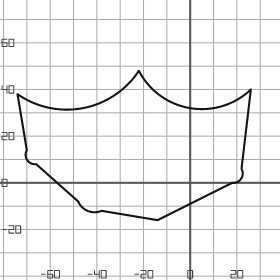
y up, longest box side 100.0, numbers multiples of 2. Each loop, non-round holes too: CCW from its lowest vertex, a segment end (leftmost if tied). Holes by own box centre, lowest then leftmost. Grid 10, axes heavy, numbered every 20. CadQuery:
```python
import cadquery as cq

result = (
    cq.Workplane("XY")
    .moveTo(-14.0, -16.0)
    .lineTo(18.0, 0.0)
    .threePointArc((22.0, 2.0), (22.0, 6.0))
    .lineTo(26.0, 40.0)
    .threePointArc((0.0, 32.0), (-22.0, 48.0))
    .threePointArc((-46.0, 32.0), (-74.0, 38.0))
    .lineTo(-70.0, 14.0)
    .threePointArc((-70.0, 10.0), (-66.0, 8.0))
    .lineTo(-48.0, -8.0)
    .threePointArc((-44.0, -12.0), (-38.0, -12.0))
    .close()
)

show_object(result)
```